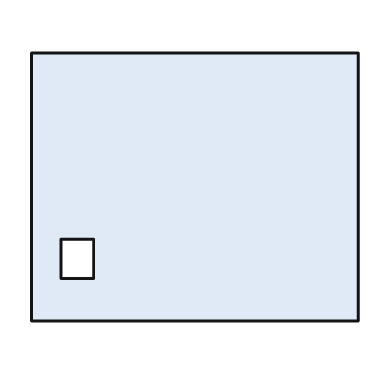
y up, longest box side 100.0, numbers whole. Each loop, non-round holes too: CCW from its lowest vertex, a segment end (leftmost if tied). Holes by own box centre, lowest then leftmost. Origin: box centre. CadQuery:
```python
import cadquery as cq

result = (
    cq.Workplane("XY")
    .moveTo(-50.0, -41.0)
    .lineTo(50.0, -41.0)
    .lineTo(50.0, 41.0)
    .lineTo(-50.0, 41.0)
    .close()
    .moveTo(-41.0, -28.0)
    .lineTo(-31.0, -28.0)
    .lineTo(-31.0, -16.0)
    .lineTo(-41.0, -16.0)
    .close()
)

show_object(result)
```